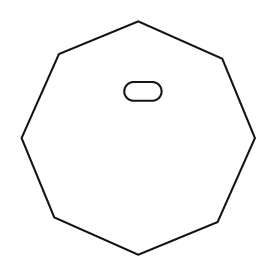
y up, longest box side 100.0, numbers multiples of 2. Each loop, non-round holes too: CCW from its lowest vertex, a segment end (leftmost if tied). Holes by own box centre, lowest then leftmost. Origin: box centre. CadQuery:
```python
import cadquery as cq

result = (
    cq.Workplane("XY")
    .moveTo(0.0, -50.0)
    .lineTo(34.0, -36.0)
    .lineTo(50.0, 0.0)
    .lineTo(36.0, 34.0)
    .lineTo(0.0, 50.0)
    .lineTo(-34.0, 36.0)
    .lineTo(-50.0, 0.0)
    .lineTo(-36.0, -34.0)
    .close()
    .moveTo(-2.0, 16.0)
    .lineTo(6.0, 16.0)
    .threePointArc((10.0, 20.0), (6.0, 24.0))
    .lineTo(-2.0, 24.0)
    .threePointArc((-6.0, 20.0), (-2.0, 16.0))
    .close()
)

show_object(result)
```